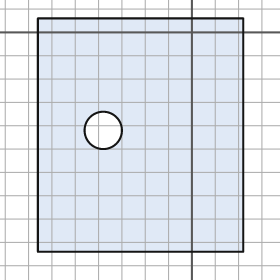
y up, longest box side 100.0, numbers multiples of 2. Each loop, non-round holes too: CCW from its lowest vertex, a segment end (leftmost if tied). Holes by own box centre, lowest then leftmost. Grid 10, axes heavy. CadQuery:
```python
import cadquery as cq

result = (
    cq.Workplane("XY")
    .moveTo(-66.0, -94.0)
    .lineTo(22.0, -94.0)
    .lineTo(22.0, 6.0)
    .lineTo(-66.0, 6.0)
    .close()
    .moveTo(-38.0, -42.0)
    .circle(8.0)
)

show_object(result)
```